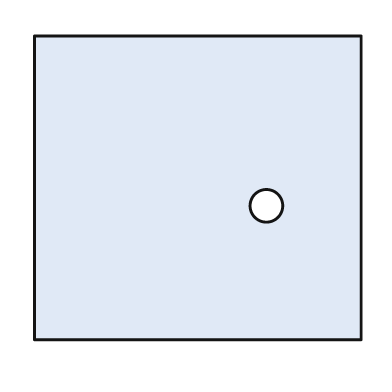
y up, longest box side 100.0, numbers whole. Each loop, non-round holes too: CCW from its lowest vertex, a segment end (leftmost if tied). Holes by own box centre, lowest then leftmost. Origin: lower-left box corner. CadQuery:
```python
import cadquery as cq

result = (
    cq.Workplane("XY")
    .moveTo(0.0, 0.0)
    .lineTo(100.0, 0.0)
    .lineTo(100.0, 93.0)
    .lineTo(0.0, 93.0)
    .close()
    .moveTo(71.0, 41.0)
    .circle(5.0)
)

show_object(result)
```